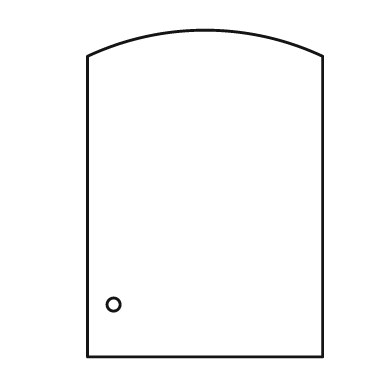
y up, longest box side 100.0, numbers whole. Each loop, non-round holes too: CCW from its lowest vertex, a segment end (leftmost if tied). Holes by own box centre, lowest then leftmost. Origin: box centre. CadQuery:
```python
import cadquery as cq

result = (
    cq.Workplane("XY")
    .moveTo(-36.0, -50.0)
    .lineTo(36.0, -50.0)
    .lineTo(36.0, 42.0)
    .threePointArc((0.0, 50.0), (-36.0, 42.0))
    .close()
    .moveTo(-28.0, -34.0)
    .circle(2.0)
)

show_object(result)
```